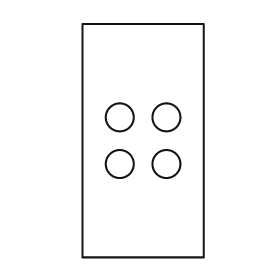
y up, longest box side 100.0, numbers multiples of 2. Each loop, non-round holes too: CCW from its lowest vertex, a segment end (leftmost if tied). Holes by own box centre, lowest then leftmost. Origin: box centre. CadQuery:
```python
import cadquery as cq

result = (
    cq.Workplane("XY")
    .moveTo(-26.0, -50.0)
    .lineTo(26.0, -50.0)
    .lineTo(26.0, 50.0)
    .lineTo(-26.0, 50.0)
    .close()
    .moveTo(-10.0, -10.0)
    .circle(6.0)
    .moveTo(10.0, -10.0)
    .circle(6.0)
    .moveTo(-10.0, 10.0)
    .circle(6.0)
    .moveTo(10.0, 10.0)
    .circle(6.0)
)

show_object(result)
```